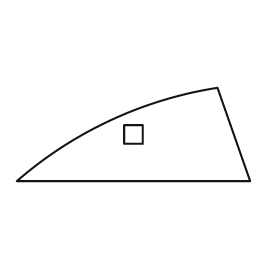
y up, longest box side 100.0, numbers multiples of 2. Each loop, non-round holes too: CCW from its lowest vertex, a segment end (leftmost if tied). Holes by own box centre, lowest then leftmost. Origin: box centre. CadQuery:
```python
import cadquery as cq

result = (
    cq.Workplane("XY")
    .moveTo(-50.0, -20.0)
    .lineTo(50.0, -20.0)
    .lineTo(36.0, 20.0)
    .threePointArc((-10.0, 6.0), (-50.0, -20.0))
    .close()
    .moveTo(-4.0, -4.0)
    .lineTo(4.0, -4.0)
    .lineTo(4.0, 4.0)
    .lineTo(-4.0, 4.0)
    .close()
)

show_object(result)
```